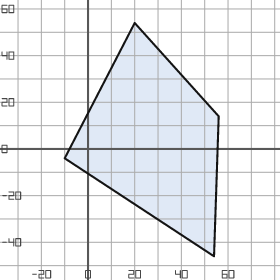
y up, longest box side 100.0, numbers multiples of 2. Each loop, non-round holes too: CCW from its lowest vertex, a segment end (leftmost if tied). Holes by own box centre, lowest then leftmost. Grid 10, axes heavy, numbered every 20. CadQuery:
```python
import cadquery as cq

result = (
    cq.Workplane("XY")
    .moveTo(54.0, -46.0)
    .lineTo(56.0, 14.0)
    .lineTo(20.0, 54.0)
    .lineTo(-10.0, -4.0)
    .close()
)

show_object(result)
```